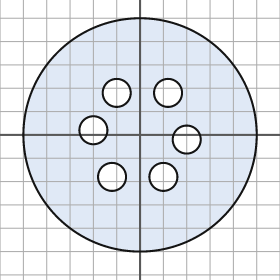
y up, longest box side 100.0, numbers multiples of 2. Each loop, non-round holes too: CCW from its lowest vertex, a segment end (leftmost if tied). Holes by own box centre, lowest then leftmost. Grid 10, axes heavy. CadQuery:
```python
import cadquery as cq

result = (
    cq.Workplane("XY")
    .moveTo(0.0, 0.0)
    .circle(50.0)
    .moveTo(-12.0, -18.0)
    .circle(6.0)
    .moveTo(10.0, -18.0)
    .circle(6.0)
    .moveTo(20.0, -2.0)
    .circle(6.0)
    .moveTo(-20.0, 2.0)
    .circle(6.0)
    .moveTo(-10.0, 18.0)
    .circle(6.0)
    .moveTo(12.0, 18.0)
    .circle(6.0)
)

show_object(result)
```